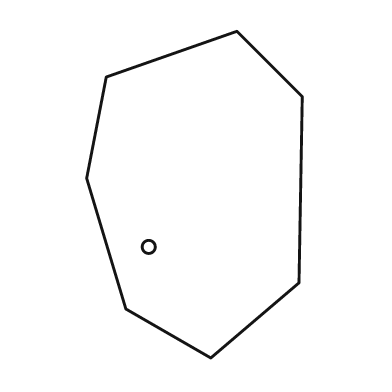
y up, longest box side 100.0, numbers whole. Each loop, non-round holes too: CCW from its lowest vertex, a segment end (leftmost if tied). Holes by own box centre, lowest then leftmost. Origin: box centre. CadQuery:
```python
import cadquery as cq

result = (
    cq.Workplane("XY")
    .moveTo(5.0, -50.0)
    .lineTo(32.0, -27.0)
    .lineTo(33.0, 30.0)
    .lineTo(13.0, 50.0)
    .lineTo(-27.0, 36.0)
    .lineTo(-33.0, 5.0)
    .lineTo(-21.0, -35.0)
    .close()
    .moveTo(-14.0, -16.0)
    .circle(2.0)
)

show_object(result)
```